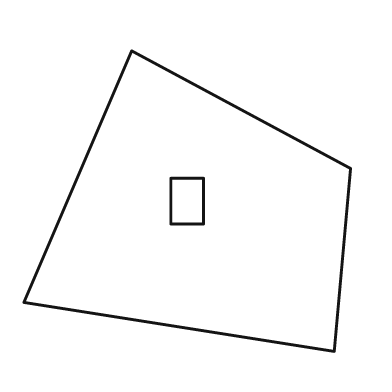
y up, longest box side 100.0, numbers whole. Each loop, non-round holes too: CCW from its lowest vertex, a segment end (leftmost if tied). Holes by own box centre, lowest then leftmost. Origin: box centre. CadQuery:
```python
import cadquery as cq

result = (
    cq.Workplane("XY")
    .moveTo(45.0, -46.0)
    .lineTo(50.0, 10.0)
    .lineTo(-17.0, 46.0)
    .lineTo(-50.0, -31.0)
    .close()
    .moveTo(-5.0, -7.0)
    .lineTo(5.0, -7.0)
    .lineTo(5.0, 7.0)
    .lineTo(-5.0, 7.0)
    .close()
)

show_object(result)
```